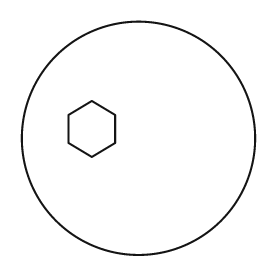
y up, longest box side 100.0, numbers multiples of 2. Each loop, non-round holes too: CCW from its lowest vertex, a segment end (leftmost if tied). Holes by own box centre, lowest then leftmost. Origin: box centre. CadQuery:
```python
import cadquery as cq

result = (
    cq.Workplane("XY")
    .moveTo(0.0, 0.0)
    .circle(50.0)
    .moveTo(-20.0, -8.0)
    .lineTo(-10.0, -2.0)
    .lineTo(-10.0, 10.0)
    .lineTo(-20.0, 16.0)
    .lineTo(-30.0, 10.0)
    .lineTo(-30.0, -2.0)
    .close()
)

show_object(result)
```